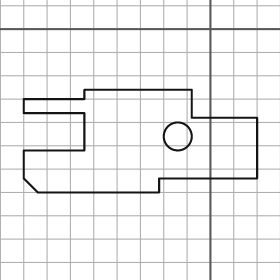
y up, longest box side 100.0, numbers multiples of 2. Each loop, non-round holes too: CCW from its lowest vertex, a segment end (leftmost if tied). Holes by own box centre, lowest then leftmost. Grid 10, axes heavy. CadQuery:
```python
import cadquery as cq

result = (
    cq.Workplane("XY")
    .moveTo(-74.0, -70.0)
    .lineTo(-22.0, -70.0)
    .lineTo(-22.0, -64.0)
    .lineTo(20.0, -64.0)
    .lineTo(20.0, -38.0)
    .lineTo(-8.0, -38.0)
    .lineTo(-8.0, -26.0)
    .lineTo(-54.0, -26.0)
    .lineTo(-54.0, -30.0)
    .lineTo(-80.0, -30.0)
    .lineTo(-80.0, -36.0)
    .lineTo(-54.0, -36.0)
    .lineTo(-54.0, -52.0)
    .lineTo(-80.0, -52.0)
    .lineTo(-80.0, -64.0)
    .close()
    .moveTo(-14.0, -46.0)
    .circle(6.0)
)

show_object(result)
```